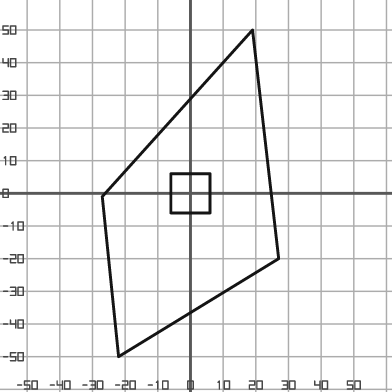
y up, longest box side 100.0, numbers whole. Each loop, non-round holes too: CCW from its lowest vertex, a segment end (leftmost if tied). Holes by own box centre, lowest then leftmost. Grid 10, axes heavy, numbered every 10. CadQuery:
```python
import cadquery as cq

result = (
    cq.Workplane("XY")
    .moveTo(-22.0, -50.0)
    .lineTo(27.0, -20.0)
    .lineTo(19.0, 50.0)
    .lineTo(-27.0, -1.0)
    .close()
    .moveTo(-6.0, -6.0)
    .lineTo(6.0, -6.0)
    .lineTo(6.0, 6.0)
    .lineTo(-6.0, 6.0)
    .close()
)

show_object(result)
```